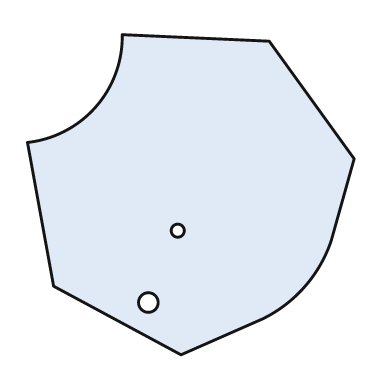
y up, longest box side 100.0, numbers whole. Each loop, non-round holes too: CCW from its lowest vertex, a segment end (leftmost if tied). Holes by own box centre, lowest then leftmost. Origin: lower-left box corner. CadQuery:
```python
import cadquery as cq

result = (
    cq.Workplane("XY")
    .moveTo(47.0, 0.0)
    .lineTo(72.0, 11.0)
    .threePointArc((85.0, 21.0), (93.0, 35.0))
    .lineTo(100.0, 60.0)
    .lineTo(74.0, 96.0)
    .lineTo(29.0, 98.0)
    .threePointArc((21.0, 76.0), (0.0, 65.0))
    .lineTo(8.0, 21.0)
    .close()
    .moveTo(37.0, 16.0)
    .circle(3.0)
    .moveTo(46.0, 38.0)
    .circle(2.0)
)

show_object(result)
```